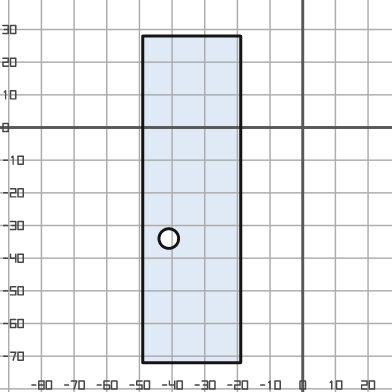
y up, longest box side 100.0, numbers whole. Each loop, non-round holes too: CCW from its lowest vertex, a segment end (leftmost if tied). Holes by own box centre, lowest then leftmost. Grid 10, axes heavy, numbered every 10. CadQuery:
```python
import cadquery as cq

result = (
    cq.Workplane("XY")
    .moveTo(-49.0, -72.0)
    .lineTo(-19.0, -72.0)
    .lineTo(-19.0, 28.0)
    .lineTo(-49.0, 28.0)
    .close()
    .moveTo(-41.0, -34.0)
    .circle(3.0)
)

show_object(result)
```